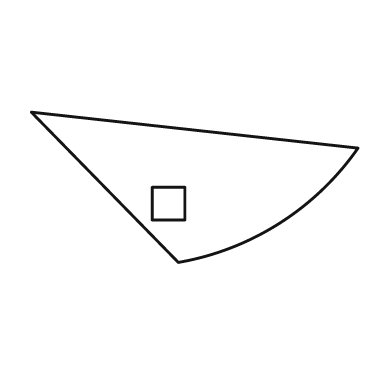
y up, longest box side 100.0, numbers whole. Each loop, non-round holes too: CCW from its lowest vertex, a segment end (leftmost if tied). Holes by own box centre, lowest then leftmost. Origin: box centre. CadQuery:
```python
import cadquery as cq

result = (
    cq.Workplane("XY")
    .moveTo(-5.0, -23.0)
    .threePointArc((26.0, -11.0), (50.0, 12.0))
    .lineTo(-50.0, 23.0)
    .close()
    .moveTo(-13.0, -10.0)
    .lineTo(-3.0, -10.0)
    .lineTo(-3.0, 0.0)
    .lineTo(-13.0, 0.0)
    .close()
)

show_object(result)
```